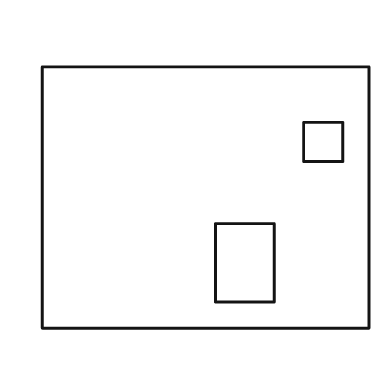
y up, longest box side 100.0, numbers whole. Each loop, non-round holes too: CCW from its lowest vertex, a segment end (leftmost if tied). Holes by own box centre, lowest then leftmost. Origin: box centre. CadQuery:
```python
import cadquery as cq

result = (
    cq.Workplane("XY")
    .moveTo(-50.0, -40.0)
    .lineTo(50.0, -40.0)
    .lineTo(50.0, 40.0)
    .lineTo(-50.0, 40.0)
    .close()
    .moveTo(3.0, -32.0)
    .lineTo(21.0, -32.0)
    .lineTo(21.0, -8.0)
    .lineTo(3.0, -8.0)
    .close()
    .moveTo(30.0, 11.0)
    .lineTo(42.0, 11.0)
    .lineTo(42.0, 23.0)
    .lineTo(30.0, 23.0)
    .close()
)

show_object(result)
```